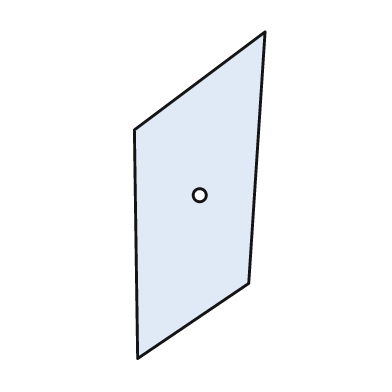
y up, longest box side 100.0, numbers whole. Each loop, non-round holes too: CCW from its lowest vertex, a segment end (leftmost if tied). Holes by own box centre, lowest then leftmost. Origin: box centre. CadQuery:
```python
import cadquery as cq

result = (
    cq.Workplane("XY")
    .moveTo(-19.0, -50.0)
    .lineTo(15.0, -27.0)
    .lineTo(20.0, 50.0)
    .lineTo(-20.0, 20.0)
    .close()
    .moveTo(0.0, 0.0)
    .circle(2.0)
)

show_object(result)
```